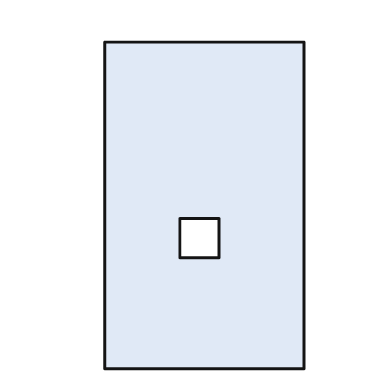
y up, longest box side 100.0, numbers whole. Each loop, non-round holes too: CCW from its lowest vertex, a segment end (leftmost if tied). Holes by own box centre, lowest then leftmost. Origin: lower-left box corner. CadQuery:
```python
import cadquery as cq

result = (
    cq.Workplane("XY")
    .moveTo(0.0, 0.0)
    .lineTo(61.0, 0.0)
    .lineTo(61.0, 100.0)
    .lineTo(0.0, 100.0)
    .close()
    .moveTo(23.0, 34.0)
    .lineTo(35.0, 34.0)
    .lineTo(35.0, 46.0)
    .lineTo(23.0, 46.0)
    .close()
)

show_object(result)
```